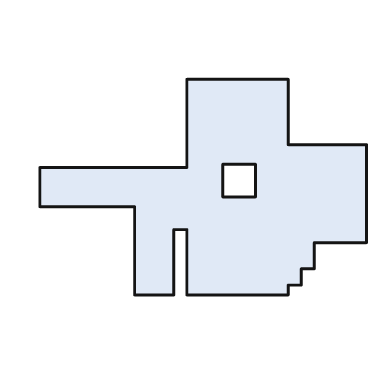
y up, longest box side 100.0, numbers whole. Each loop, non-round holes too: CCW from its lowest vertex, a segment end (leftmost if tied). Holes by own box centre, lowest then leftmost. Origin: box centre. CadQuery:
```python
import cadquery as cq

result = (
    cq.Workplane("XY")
    .moveTo(-21.0, -33.0)
    .lineTo(-9.0, -33.0)
    .lineTo(-9.0, -13.0)
    .lineTo(-5.0, -13.0)
    .lineTo(-5.0, -33.0)
    .lineTo(26.0, -33.0)
    .lineTo(26.0, -30.0)
    .lineTo(30.0, -30.0)
    .lineTo(30.0, -25.0)
    .lineTo(34.0, -25.0)
    .lineTo(34.0, -17.0)
    .lineTo(50.0, -17.0)
    .lineTo(50.0, 13.0)
    .lineTo(26.0, 13.0)
    .lineTo(26.0, 33.0)
    .lineTo(-5.0, 33.0)
    .lineTo(-5.0, 6.0)
    .lineTo(-50.0, 6.0)
    .lineTo(-50.0, -6.0)
    .lineTo(-21.0, -6.0)
    .close()
    .moveTo(6.0, -3.0)
    .lineTo(16.0, -3.0)
    .lineTo(16.0, 7.0)
    .lineTo(6.0, 7.0)
    .close()
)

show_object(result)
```